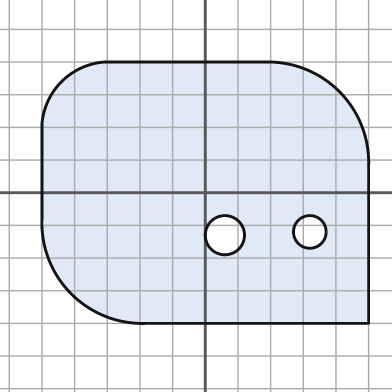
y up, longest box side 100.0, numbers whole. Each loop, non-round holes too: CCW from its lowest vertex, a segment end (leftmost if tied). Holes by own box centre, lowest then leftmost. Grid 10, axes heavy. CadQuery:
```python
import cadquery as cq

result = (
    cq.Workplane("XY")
    .moveTo(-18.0, -40.0)
    .lineTo(50.0, -40.0)
    .lineTo(50.0, 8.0)
    .threePointArc((41.0, 31.0), (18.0, 40.0))
    .lineTo(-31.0, 40.0)
    .threePointArc((-44.0, 34.0), (-50.0, 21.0))
    .lineTo(-50.0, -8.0)
    .threePointArc((-41.0, -31.0), (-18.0, -40.0))
    .close()
    .moveTo(6.0, -13.0)
    .circle(6.0)
    .moveTo(32.0, -12.0)
    .circle(5.0)
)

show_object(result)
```